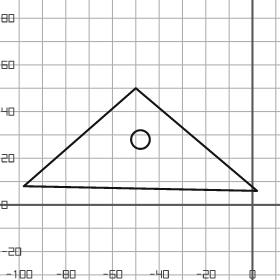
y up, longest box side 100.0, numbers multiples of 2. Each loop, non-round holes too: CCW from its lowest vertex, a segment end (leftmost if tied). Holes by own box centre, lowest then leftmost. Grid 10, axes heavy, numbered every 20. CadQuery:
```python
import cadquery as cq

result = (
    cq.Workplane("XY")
    .moveTo(2.0, 6.0)
    .lineTo(-50.0, 50.0)
    .lineTo(-98.0, 8.0)
    .close()
    .moveTo(-48.0, 28.0)
    .circle(4.0)
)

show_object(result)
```